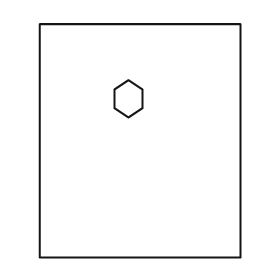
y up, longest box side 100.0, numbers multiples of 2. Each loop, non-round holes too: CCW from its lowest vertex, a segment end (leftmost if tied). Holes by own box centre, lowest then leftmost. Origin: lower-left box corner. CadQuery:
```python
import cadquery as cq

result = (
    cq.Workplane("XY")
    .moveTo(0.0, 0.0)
    .lineTo(86.0, 0.0)
    .lineTo(86.0, 100.0)
    .lineTo(0.0, 100.0)
    .close()
    .moveTo(38.0, 60.0)
    .lineTo(44.0, 64.0)
    .lineTo(44.0, 72.0)
    .lineTo(38.0, 76.0)
    .lineTo(32.0, 72.0)
    .lineTo(32.0, 64.0)
    .close()
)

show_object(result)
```